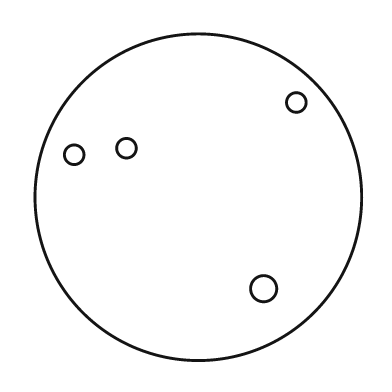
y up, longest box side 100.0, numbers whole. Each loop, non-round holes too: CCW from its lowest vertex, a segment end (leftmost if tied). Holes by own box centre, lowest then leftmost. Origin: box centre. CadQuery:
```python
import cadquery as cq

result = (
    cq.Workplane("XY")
    .moveTo(0.0, 0.0)
    .circle(50.0)
    .moveTo(20.0, -28.0)
    .circle(4.0)
    .moveTo(-38.0, 13.0)
    .circle(3.0)
    .moveTo(-22.0, 15.0)
    .circle(3.0)
    .moveTo(30.0, 29.0)
    .circle(3.0)
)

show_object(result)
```